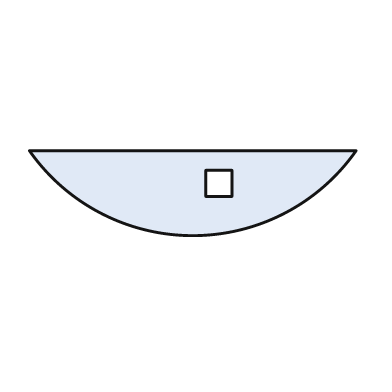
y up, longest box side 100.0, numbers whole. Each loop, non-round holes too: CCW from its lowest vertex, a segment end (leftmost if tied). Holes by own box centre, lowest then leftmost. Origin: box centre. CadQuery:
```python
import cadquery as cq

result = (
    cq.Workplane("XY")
    .moveTo(-50.0, 13.0)
    .threePointArc((0.0, -13.0), (50.0, 13.0))
    .close()
    .moveTo(4.0, -1.0)
    .lineTo(12.0, -1.0)
    .lineTo(12.0, 7.0)
    .lineTo(4.0, 7.0)
    .close()
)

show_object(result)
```